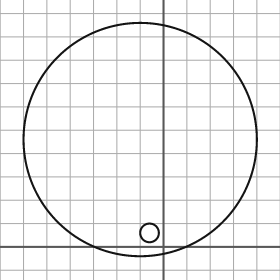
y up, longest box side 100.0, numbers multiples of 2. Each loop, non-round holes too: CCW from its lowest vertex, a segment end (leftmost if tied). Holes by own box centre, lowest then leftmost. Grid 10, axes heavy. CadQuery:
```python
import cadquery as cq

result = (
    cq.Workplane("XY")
    .moveTo(-10.0, 46.0)
    .circle(50.0)
    .moveTo(-6.0, 6.0)
    .circle(4.0)
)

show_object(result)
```